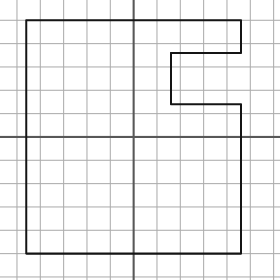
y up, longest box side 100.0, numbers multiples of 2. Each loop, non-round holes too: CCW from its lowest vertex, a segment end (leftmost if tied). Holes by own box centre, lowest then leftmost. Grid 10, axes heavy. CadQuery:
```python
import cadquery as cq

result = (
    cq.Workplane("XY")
    .moveTo(-46.0, -50.0)
    .lineTo(46.0, -50.0)
    .lineTo(46.0, 14.0)
    .lineTo(16.0, 14.0)
    .lineTo(16.0, 36.0)
    .lineTo(46.0, 36.0)
    .lineTo(46.0, 50.0)
    .lineTo(-46.0, 50.0)
    .close()
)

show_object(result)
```